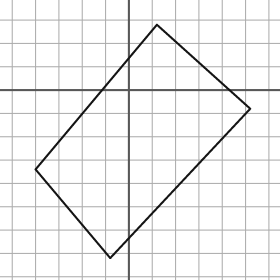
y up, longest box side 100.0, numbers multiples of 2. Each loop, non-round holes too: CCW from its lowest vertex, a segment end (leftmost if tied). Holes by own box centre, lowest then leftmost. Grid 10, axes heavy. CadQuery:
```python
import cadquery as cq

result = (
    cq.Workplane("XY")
    .moveTo(-8.0, -72.0)
    .lineTo(52.0, -8.0)
    .lineTo(12.0, 28.0)
    .lineTo(-40.0, -34.0)
    .close()
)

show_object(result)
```